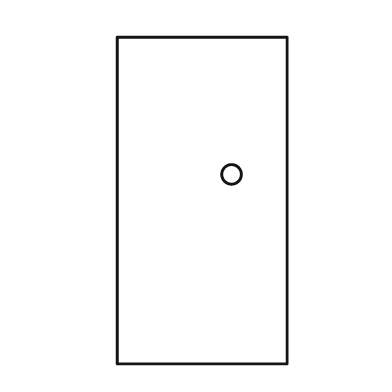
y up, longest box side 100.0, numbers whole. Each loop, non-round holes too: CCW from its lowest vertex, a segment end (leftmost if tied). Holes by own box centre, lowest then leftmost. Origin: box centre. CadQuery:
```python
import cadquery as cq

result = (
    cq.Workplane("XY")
    .moveTo(-26.0, -50.0)
    .lineTo(26.0, -50.0)
    .lineTo(26.0, 50.0)
    .lineTo(-26.0, 50.0)
    .close()
    .moveTo(9.0, 8.0)
    .circle(3.0)
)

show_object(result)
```